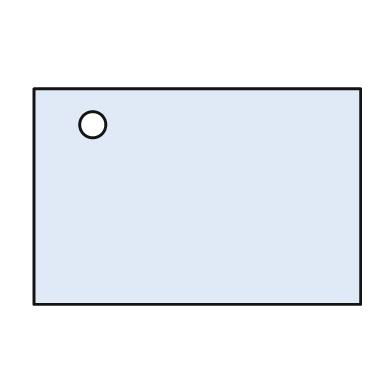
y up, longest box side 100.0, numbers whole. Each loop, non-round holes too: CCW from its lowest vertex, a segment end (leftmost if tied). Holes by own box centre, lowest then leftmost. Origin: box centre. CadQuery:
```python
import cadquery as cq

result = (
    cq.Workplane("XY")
    .moveTo(-50.0, -33.0)
    .lineTo(50.0, -33.0)
    .lineTo(50.0, 33.0)
    .lineTo(-50.0, 33.0)
    .close()
    .moveTo(-32.0, 22.0)
    .circle(4.0)
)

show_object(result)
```